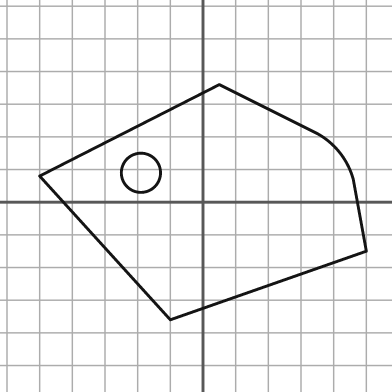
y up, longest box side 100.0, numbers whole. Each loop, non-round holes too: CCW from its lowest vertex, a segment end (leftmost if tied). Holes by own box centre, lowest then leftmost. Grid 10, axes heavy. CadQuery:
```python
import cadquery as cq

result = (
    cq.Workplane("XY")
    .moveTo(-10.0, -36.0)
    .lineTo(50.0, -15.0)
    .lineTo(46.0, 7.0)
    .threePointArc((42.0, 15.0), (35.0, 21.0))
    .lineTo(5.0, 36.0)
    .lineTo(-50.0, 8.0)
    .close()
    .moveTo(-19.0, 9.0)
    .circle(6.0)
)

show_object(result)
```